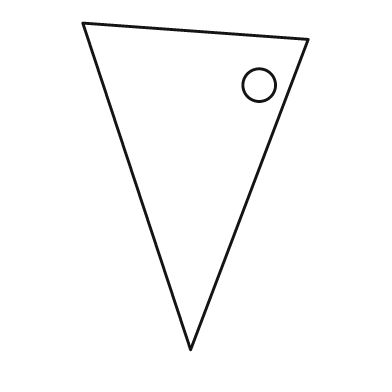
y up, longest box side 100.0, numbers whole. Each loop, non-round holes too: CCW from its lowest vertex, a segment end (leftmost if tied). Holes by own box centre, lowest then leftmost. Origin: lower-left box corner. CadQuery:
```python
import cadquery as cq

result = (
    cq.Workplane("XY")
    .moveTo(33.0, 0.0)
    .lineTo(69.0, 95.0)
    .lineTo(0.0, 100.0)
    .close()
    .moveTo(54.0, 81.0)
    .circle(5.0)
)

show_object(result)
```